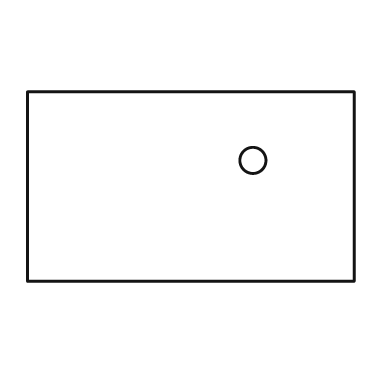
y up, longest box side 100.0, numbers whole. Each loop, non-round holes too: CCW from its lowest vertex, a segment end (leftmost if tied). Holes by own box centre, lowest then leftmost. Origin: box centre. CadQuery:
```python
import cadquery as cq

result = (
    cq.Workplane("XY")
    .moveTo(-50.0, -29.0)
    .lineTo(50.0, -29.0)
    .lineTo(50.0, 29.0)
    .lineTo(-50.0, 29.0)
    .close()
    .moveTo(19.0, 8.0)
    .circle(4.0)
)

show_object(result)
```